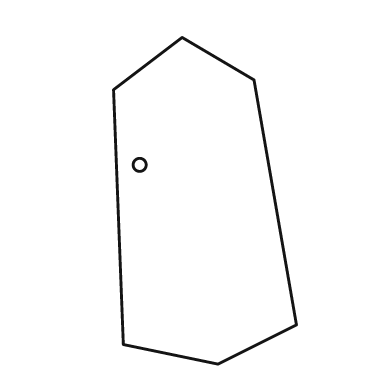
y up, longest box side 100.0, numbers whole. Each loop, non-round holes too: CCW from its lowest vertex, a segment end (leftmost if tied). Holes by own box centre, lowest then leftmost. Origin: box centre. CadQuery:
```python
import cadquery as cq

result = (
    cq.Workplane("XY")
    .moveTo(4.0, -50.0)
    .lineTo(28.0, -38.0)
    .lineTo(15.0, 37.0)
    .lineTo(-7.0, 50.0)
    .lineTo(-28.0, 34.0)
    .lineTo(-25.0, -44.0)
    .close()
    .moveTo(-20.0, 11.0)
    .circle(2.0)
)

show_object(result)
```